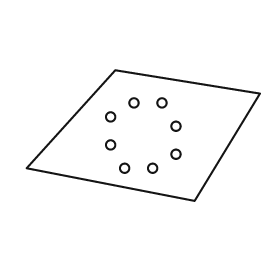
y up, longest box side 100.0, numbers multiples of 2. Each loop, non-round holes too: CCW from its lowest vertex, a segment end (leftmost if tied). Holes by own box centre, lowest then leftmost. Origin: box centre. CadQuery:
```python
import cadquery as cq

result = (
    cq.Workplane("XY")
    .moveTo(22.0, -28.0)
    .lineTo(50.0, 18.0)
    .lineTo(-12.0, 28.0)
    .lineTo(-50.0, -14.0)
    .close()
    .moveTo(-8.0, -14.0)
    .circle(2.0)
    .moveTo(4.0, -14.0)
    .circle(2.0)
    .moveTo(14.0, -8.0)
    .circle(2.0)
    .moveTo(-14.0, -4.0)
    .circle(2.0)
    .moveTo(14.0, 4.0)
    .circle(2.0)
    .moveTo(-14.0, 8.0)
    .circle(2.0)
    .moveTo(-4.0, 14.0)
    .circle(2.0)
    .moveTo(8.0, 14.0)
    .circle(2.0)
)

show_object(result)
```